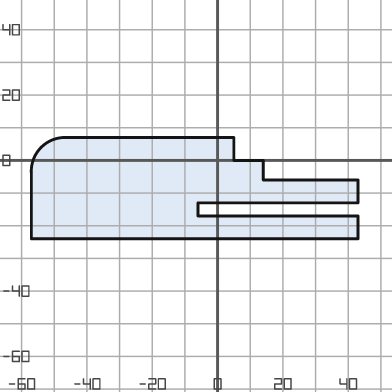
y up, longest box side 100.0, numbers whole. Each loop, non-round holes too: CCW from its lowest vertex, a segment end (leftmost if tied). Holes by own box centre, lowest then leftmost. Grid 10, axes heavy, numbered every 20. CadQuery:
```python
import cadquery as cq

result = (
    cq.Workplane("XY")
    .moveTo(-57.0, -24.0)
    .lineTo(43.0, -24.0)
    .lineTo(43.0, -17.0)
    .lineTo(-6.0, -17.0)
    .lineTo(-6.0, -13.0)
    .lineTo(43.0, -13.0)
    .lineTo(43.0, -6.0)
    .lineTo(14.0, -6.0)
    .lineTo(14.0, 0.0)
    .lineTo(5.0, 0.0)
    .lineTo(5.0, 7.0)
    .lineTo(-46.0, 7.0)
    .threePointArc((-54.0, 4.0), (-57.0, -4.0))
    .close()
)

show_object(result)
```